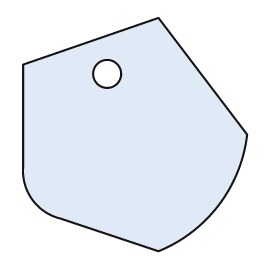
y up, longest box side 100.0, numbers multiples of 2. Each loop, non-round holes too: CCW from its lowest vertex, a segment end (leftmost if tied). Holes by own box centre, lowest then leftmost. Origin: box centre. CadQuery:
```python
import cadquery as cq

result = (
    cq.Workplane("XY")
    .moveTo(10.0, -50.0)
    .threePointArc((36.0, -30.0), (48.0, 0.0))
    .lineTo(10.0, 50.0)
    .lineTo(-48.0, 30.0)
    .lineTo(-48.0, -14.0)
    .threePointArc((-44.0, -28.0), (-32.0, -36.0))
    .close()
    .moveTo(-12.0, 26.0)
    .circle(6.0)
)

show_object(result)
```